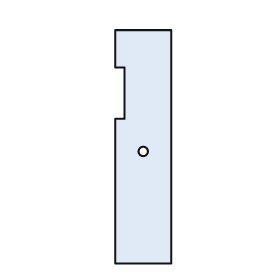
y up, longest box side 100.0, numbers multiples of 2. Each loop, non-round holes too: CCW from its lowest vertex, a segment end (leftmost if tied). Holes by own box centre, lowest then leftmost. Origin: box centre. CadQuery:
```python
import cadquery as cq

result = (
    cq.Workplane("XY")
    .moveTo(-12.0, -50.0)
    .lineTo(12.0, -50.0)
    .lineTo(12.0, 50.0)
    .lineTo(-12.0, 50.0)
    .lineTo(-12.0, 34.0)
    .lineTo(-8.0, 34.0)
    .lineTo(-8.0, 12.0)
    .lineTo(-12.0, 12.0)
    .close()
    .moveTo(0.0, -2.0)
    .circle(2.0)
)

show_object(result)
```